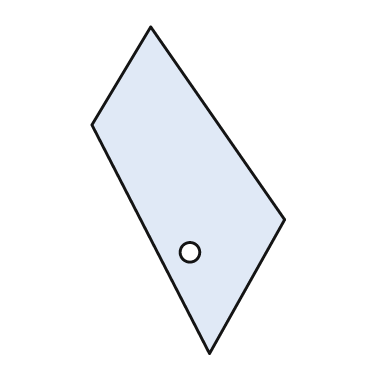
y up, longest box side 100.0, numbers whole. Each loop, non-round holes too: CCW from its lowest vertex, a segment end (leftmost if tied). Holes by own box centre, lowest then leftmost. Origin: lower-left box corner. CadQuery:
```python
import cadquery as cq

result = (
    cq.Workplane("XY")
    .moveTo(36.0, 0.0)
    .lineTo(59.0, 41.0)
    .lineTo(18.0, 100.0)
    .lineTo(0.0, 70.0)
    .close()
    .moveTo(30.0, 31.0)
    .circle(3.0)
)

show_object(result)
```